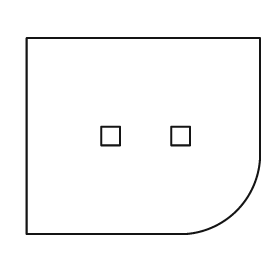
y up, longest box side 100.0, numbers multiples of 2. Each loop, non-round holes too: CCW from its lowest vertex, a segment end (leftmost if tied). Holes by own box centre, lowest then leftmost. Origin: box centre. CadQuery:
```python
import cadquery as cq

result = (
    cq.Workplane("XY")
    .moveTo(-50.0, -42.0)
    .lineTo(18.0, -42.0)
    .threePointArc((40.0, -32.0), (50.0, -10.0))
    .lineTo(50.0, 42.0)
    .lineTo(-50.0, 42.0)
    .close()
    .moveTo(-18.0, -4.0)
    .lineTo(-10.0, -4.0)
    .lineTo(-10.0, 4.0)
    .lineTo(-18.0, 4.0)
    .close()
    .moveTo(12.0, -4.0)
    .lineTo(20.0, -4.0)
    .lineTo(20.0, 4.0)
    .lineTo(12.0, 4.0)
    .close()
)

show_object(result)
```